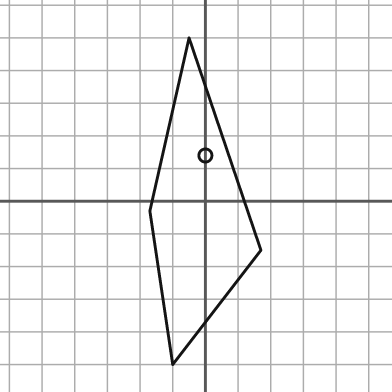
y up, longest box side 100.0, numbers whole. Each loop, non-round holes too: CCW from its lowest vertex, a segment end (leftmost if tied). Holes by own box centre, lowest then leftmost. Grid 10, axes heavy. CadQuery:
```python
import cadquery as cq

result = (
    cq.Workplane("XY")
    .moveTo(-10.0, -50.0)
    .lineTo(17.0, -15.0)
    .lineTo(-5.0, 50.0)
    .lineTo(-17.0, -3.0)
    .close()
    .moveTo(0.0, 14.0)
    .circle(2.0)
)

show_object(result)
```